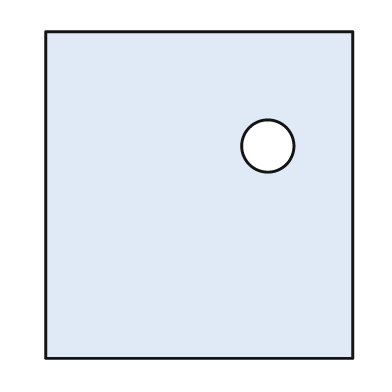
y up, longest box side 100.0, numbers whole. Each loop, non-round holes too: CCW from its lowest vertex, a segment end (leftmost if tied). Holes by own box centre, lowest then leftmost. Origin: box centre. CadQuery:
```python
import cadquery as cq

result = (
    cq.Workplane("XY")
    .moveTo(-47.0, -50.0)
    .lineTo(47.0, -50.0)
    .lineTo(47.0, 50.0)
    .lineTo(-47.0, 50.0)
    .close()
    .moveTo(21.0, 15.0)
    .circle(8.0)
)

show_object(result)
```